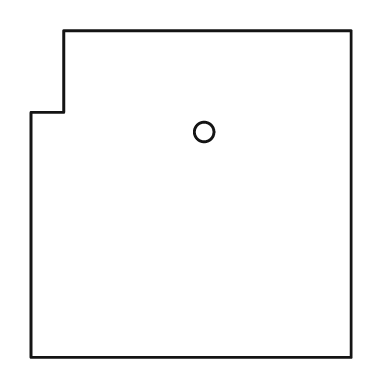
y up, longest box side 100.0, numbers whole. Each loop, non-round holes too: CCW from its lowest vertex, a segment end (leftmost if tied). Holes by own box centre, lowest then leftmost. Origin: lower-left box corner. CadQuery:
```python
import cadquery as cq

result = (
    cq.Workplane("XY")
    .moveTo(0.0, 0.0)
    .lineTo(98.0, 0.0)
    .lineTo(98.0, 100.0)
    .lineTo(10.0, 100.0)
    .lineTo(10.0, 75.0)
    .lineTo(0.0, 75.0)
    .close()
    .moveTo(53.0, 69.0)
    .circle(3.0)
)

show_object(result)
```